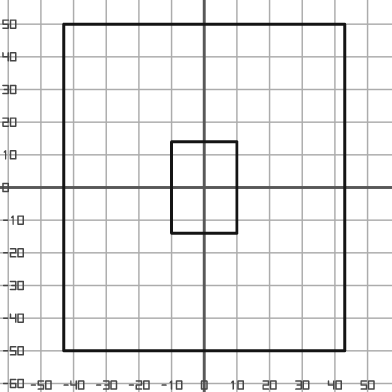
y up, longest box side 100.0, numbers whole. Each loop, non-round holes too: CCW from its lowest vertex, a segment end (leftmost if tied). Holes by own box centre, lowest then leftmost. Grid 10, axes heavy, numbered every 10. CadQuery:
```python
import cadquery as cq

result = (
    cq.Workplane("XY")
    .moveTo(-43.0, -50.0)
    .lineTo(43.0, -50.0)
    .lineTo(43.0, 50.0)
    .lineTo(-43.0, 50.0)
    .close()
    .moveTo(-10.0, -14.0)
    .lineTo(10.0, -14.0)
    .lineTo(10.0, 14.0)
    .lineTo(-10.0, 14.0)
    .close()
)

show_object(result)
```